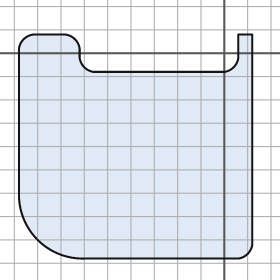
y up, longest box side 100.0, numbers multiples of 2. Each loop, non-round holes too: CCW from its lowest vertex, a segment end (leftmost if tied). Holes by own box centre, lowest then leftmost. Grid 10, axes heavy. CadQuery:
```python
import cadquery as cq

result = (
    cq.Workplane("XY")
    .moveTo(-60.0, -88.0)
    .lineTo(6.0, -88.0)
    .threePointArc((10.0, -86.0), (12.0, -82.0))
    .lineTo(12.0, 8.0)
    .lineTo(6.0, 8.0)
    .lineTo(6.0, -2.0)
    .threePointArc((4.0, -6.0), (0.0, -8.0))
    .lineTo(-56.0, -8.0)
    .threePointArc((-60.0, -6.0), (-62.0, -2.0))
    .lineTo(-62.0, 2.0)
    .threePointArc((-64.0, 6.0), (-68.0, 8.0))
    .lineTo(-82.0, 8.0)
    .threePointArc((-86.0, 6.0), (-88.0, 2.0))
    .lineTo(-88.0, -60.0)
    .threePointArc((-80.0, -80.0), (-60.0, -88.0))
    .close()
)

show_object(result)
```